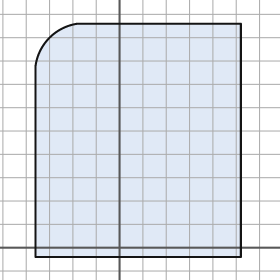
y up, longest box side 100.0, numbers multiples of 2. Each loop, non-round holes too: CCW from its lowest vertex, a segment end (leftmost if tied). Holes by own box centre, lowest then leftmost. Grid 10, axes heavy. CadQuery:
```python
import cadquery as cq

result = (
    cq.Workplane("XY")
    .moveTo(-36.0, -4.0)
    .lineTo(52.0, -4.0)
    .lineTo(52.0, 96.0)
    .lineTo(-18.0, 96.0)
    .threePointArc((-30.0, 90.0), (-36.0, 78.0))
    .close()
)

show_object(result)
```